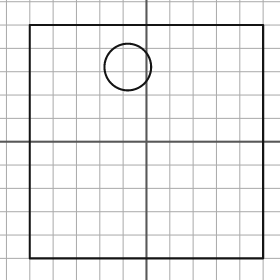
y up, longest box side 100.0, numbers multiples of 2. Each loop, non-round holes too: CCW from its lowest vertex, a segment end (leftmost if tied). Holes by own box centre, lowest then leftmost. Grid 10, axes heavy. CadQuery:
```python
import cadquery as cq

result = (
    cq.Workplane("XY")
    .moveTo(-50.0, -50.0)
    .lineTo(50.0, -50.0)
    .lineTo(50.0, 50.0)
    .lineTo(-50.0, 50.0)
    .close()
    .moveTo(-8.0, 32.0)
    .circle(10.0)
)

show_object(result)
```